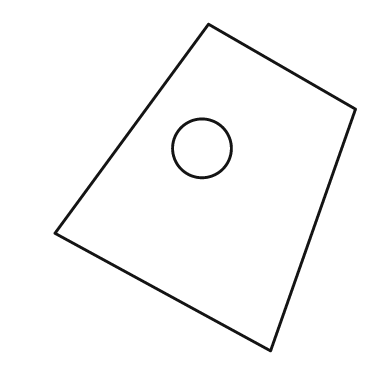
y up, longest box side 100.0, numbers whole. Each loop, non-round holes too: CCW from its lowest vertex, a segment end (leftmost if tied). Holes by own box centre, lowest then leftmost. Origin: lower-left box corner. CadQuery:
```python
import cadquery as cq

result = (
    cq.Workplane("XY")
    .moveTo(66.0, 0.0)
    .lineTo(92.0, 74.0)
    .lineTo(47.0, 100.0)
    .lineTo(0.0, 36.0)
    .close()
    .moveTo(45.0, 62.0)
    .circle(9.0)
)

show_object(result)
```